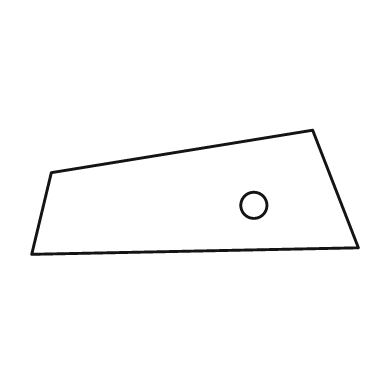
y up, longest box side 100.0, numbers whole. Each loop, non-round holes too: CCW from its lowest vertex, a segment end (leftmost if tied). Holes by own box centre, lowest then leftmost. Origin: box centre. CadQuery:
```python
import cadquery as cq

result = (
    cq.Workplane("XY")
    .moveTo(-50.0, -19.0)
    .lineTo(50.0, -17.0)
    .lineTo(36.0, 19.0)
    .lineTo(-44.0, 6.0)
    .close()
    .moveTo(18.0, -4.0)
    .circle(4.0)
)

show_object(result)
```